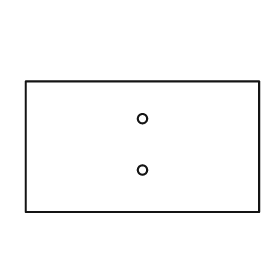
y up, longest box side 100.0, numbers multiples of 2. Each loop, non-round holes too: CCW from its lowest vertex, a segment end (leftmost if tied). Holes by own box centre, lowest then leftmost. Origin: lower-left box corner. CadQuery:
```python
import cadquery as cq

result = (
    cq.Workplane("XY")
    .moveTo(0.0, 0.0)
    .lineTo(100.0, 0.0)
    .lineTo(100.0, 56.0)
    .lineTo(0.0, 56.0)
    .close()
    .moveTo(50.0, 18.0)
    .circle(2.0)
    .moveTo(50.0, 40.0)
    .circle(2.0)
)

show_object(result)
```